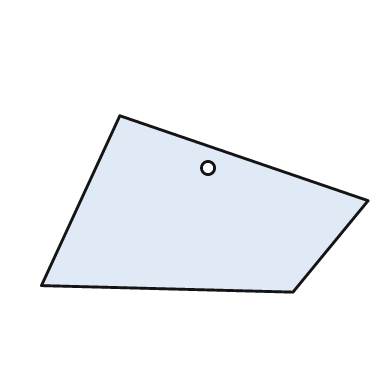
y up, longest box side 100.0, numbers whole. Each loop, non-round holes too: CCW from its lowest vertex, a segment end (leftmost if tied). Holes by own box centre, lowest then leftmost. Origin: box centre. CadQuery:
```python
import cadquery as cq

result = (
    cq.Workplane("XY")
    .moveTo(27.0, -27.0)
    .lineTo(50.0, 1.0)
    .lineTo(-26.0, 27.0)
    .lineTo(-50.0, -25.0)
    .close()
    .moveTo(1.0, 11.0)
    .circle(2.0)
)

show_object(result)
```